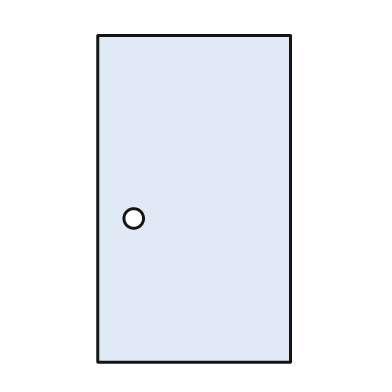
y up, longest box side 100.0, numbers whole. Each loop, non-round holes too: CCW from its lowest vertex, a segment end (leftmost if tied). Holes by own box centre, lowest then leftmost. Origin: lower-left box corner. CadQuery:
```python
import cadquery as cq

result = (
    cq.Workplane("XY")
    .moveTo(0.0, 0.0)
    .lineTo(59.0, 0.0)
    .lineTo(59.0, 100.0)
    .lineTo(0.0, 100.0)
    .close()
    .moveTo(11.0, 44.0)
    .circle(3.0)
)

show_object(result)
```